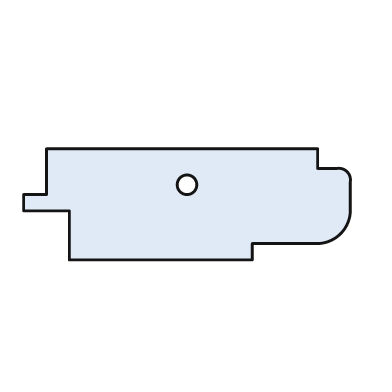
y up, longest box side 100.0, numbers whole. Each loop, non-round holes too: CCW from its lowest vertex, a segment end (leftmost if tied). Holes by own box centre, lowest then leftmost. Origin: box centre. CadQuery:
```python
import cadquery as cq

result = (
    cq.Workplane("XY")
    .moveTo(-36.0, -17.0)
    .lineTo(20.0, -17.0)
    .lineTo(20.0, -12.0)
    .lineTo(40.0, -12.0)
    .threePointArc((47.0, -9.0), (50.0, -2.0))
    .lineTo(50.0, 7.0)
    .threePointArc((49.0, 10.0), (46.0, 11.0))
    .lineTo(40.0, 11.0)
    .lineTo(40.0, 17.0)
    .lineTo(-43.0, 17.0)
    .lineTo(-43.0, 3.0)
    .lineTo(-50.0, 3.0)
    .lineTo(-50.0, -2.0)
    .lineTo(-36.0, -2.0)
    .close()
    .moveTo(0.0, 6.0)
    .circle(3.0)
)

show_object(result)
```